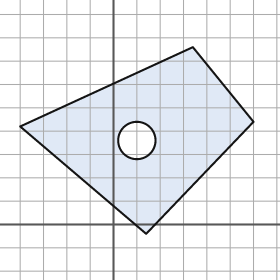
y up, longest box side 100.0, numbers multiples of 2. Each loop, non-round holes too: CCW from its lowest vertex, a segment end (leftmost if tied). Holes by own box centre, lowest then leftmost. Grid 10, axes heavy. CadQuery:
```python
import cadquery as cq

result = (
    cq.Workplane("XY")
    .moveTo(14.0, -4.0)
    .lineTo(60.0, 44.0)
    .lineTo(34.0, 76.0)
    .lineTo(-40.0, 42.0)
    .close()
    .moveTo(10.0, 36.0)
    .circle(8.0)
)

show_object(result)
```